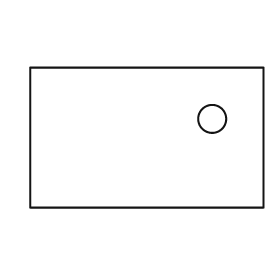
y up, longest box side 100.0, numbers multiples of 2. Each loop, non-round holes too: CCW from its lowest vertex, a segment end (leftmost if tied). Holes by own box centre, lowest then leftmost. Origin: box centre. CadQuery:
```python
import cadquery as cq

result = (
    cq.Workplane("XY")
    .moveTo(-50.0, -30.0)
    .lineTo(50.0, -30.0)
    .lineTo(50.0, 30.0)
    .lineTo(-50.0, 30.0)
    .close()
    .moveTo(28.0, 8.0)
    .circle(6.0)
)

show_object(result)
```